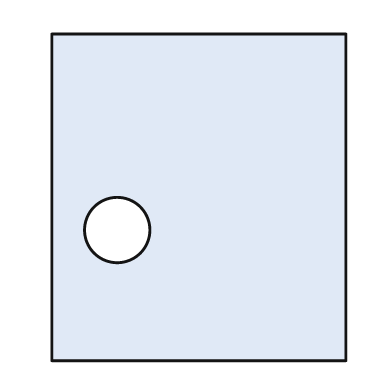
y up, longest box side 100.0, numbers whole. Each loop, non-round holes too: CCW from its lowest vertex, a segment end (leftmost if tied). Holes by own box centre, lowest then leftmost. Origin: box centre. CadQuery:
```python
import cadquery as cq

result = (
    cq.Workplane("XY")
    .moveTo(-45.0, -50.0)
    .lineTo(45.0, -50.0)
    .lineTo(45.0, 50.0)
    .lineTo(-45.0, 50.0)
    .close()
    .moveTo(-25.0, -10.0)
    .circle(10.0)
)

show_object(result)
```